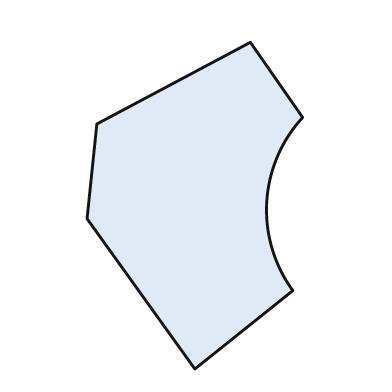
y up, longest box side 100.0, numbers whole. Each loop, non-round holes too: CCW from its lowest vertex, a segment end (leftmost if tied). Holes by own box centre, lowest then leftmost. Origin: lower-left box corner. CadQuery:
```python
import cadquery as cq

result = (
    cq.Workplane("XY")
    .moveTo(33.0, 0.0)
    .lineTo(63.0, 24.0)
    .threePointArc((55.0, 51.0), (66.0, 77.0))
    .lineTo(50.0, 100.0)
    .lineTo(3.0, 75.0)
    .lineTo(0.0, 46.0)
    .close()
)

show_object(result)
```